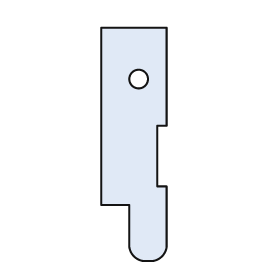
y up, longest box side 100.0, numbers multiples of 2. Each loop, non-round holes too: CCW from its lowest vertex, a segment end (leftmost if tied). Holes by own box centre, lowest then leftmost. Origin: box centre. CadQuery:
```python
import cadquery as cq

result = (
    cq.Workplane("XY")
    .moveTo(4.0, -50.0)
    .lineTo(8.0, -50.0)
    .threePointArc((12.0, -48.0), (14.0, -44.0))
    .lineTo(14.0, -18.0)
    .lineTo(10.0, -18.0)
    .lineTo(10.0, 8.0)
    .lineTo(14.0, 8.0)
    .lineTo(14.0, 50.0)
    .lineTo(-14.0, 50.0)
    .lineTo(-14.0, -26.0)
    .lineTo(-2.0, -26.0)
    .lineTo(-2.0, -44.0)
    .threePointArc((0.0, -48.0), (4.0, -50.0))
    .close()
    .moveTo(2.0, 28.0)
    .circle(4.0)
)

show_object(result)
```